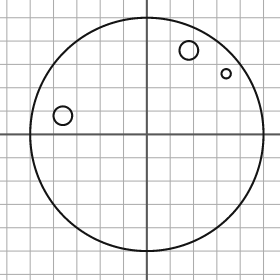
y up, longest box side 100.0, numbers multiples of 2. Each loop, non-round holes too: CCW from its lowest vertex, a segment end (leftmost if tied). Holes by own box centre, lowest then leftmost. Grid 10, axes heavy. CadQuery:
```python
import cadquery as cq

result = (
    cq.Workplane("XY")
    .moveTo(0.0, 0.0)
    .circle(50.0)
    .moveTo(-36.0, 8.0)
    .circle(4.0)
    .moveTo(34.0, 26.0)
    .circle(2.0)
    .moveTo(18.0, 36.0)
    .circle(4.0)
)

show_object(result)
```